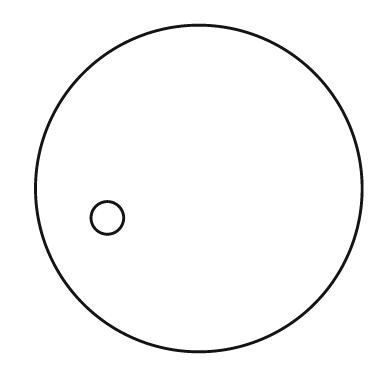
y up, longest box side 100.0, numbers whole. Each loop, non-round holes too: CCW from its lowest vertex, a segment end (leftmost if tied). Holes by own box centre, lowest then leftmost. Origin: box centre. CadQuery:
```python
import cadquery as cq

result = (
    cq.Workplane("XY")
    .moveTo(0.0, 0.0)
    .circle(50.0)
    .moveTo(-28.0, -9.0)
    .circle(5.0)
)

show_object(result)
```